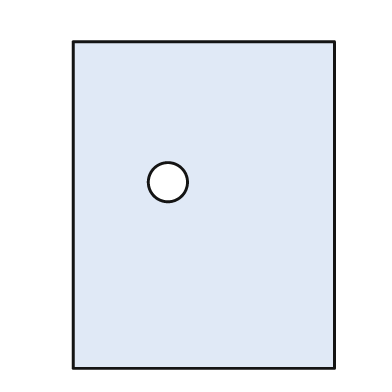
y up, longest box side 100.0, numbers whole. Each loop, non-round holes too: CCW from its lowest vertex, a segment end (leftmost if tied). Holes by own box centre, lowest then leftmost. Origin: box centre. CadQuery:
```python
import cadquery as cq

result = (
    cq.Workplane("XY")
    .moveTo(-40.0, -50.0)
    .lineTo(40.0, -50.0)
    .lineTo(40.0, 50.0)
    .lineTo(-40.0, 50.0)
    .close()
    .moveTo(-11.0, 7.0)
    .circle(6.0)
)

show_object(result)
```